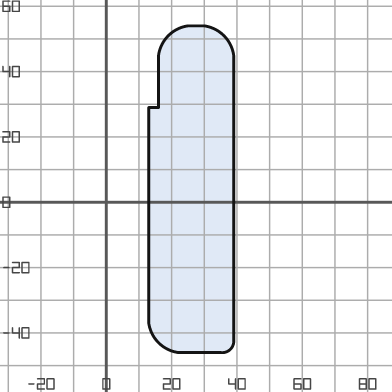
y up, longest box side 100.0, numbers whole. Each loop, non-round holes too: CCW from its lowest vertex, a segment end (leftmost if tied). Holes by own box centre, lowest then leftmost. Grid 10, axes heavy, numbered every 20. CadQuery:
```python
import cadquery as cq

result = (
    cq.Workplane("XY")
    .moveTo(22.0, -46.0)
    .lineTo(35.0, -46.0)
    .threePointArc((38.0, -45.0), (39.0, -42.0))
    .lineTo(39.0, 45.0)
    .threePointArc((36.0, 51.0), (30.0, 54.0))
    .lineTo(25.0, 54.0)
    .threePointArc((19.0, 51.0), (16.0, 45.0))
    .lineTo(16.0, 29.0)
    .lineTo(13.0, 29.0)
    .lineTo(13.0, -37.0)
    .threePointArc((16.0, -43.0), (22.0, -46.0))
    .close()
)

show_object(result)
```